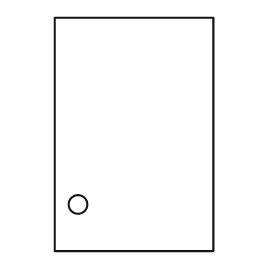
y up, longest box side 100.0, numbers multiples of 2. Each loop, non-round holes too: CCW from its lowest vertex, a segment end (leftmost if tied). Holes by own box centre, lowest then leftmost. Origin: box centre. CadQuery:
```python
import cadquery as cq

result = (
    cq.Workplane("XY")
    .moveTo(-34.0, -50.0)
    .lineTo(34.0, -50.0)
    .lineTo(34.0, 50.0)
    .lineTo(-34.0, 50.0)
    .close()
    .moveTo(-24.0, -30.0)
    .circle(4.0)
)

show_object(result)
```